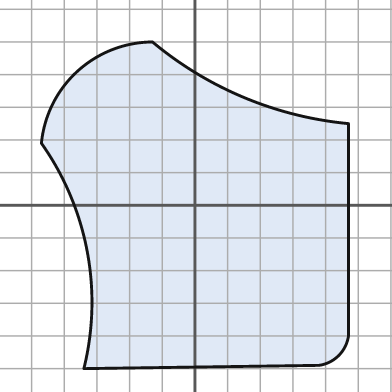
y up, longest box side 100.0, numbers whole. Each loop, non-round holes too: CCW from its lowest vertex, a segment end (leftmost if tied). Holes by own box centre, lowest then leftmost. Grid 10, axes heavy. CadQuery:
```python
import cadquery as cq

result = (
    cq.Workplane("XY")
    .moveTo(-34.0, -50.0)
    .lineTo(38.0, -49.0)
    .threePointArc((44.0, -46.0), (47.0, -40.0))
    .lineTo(47.0, 25.0)
    .threePointArc((15.0, 33.0), (-13.0, 50.0))
    .threePointArc((-36.0, 41.0), (-47.0, 19.0))
    .threePointArc((-33.0, -14.0), (-34.0, -50.0))
    .close()
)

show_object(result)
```